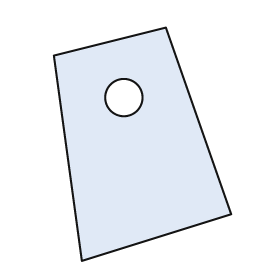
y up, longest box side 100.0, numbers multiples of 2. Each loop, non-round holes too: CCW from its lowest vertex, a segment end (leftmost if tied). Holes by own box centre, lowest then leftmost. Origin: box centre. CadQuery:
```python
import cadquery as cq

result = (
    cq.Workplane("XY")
    .moveTo(-26.0, -50.0)
    .lineTo(38.0, -30.0)
    .lineTo(10.0, 50.0)
    .lineTo(-38.0, 38.0)
    .close()
    .moveTo(-8.0, 20.0)
    .circle(8.0)
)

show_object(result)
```